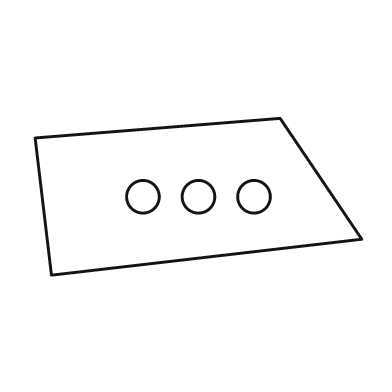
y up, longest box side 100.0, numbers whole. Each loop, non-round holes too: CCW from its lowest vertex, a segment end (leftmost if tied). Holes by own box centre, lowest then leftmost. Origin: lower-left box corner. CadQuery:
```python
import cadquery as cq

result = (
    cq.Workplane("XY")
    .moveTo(5.0, 0.0)
    .lineTo(100.0, 11.0)
    .lineTo(75.0, 48.0)
    .lineTo(0.0, 42.0)
    .close()
    .moveTo(33.0, 24.0)
    .circle(5.0)
    .moveTo(50.0, 24.0)
    .circle(5.0)
    .moveTo(67.0, 24.0)
    .circle(5.0)
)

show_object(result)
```